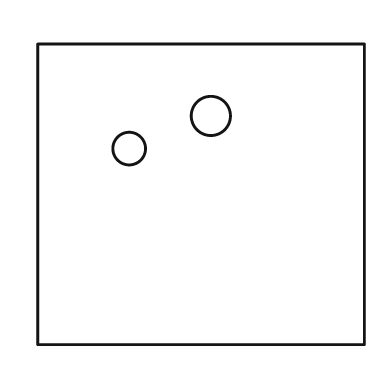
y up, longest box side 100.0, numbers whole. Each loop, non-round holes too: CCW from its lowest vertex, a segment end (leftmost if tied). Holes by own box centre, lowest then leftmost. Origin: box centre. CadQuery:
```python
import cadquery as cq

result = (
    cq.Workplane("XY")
    .moveTo(-50.0, -46.0)
    .lineTo(50.0, -46.0)
    .lineTo(50.0, 46.0)
    .lineTo(-50.0, 46.0)
    .close()
    .moveTo(-22.0, 14.0)
    .circle(5.0)
    .moveTo(3.0, 24.0)
    .circle(6.0)
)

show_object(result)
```